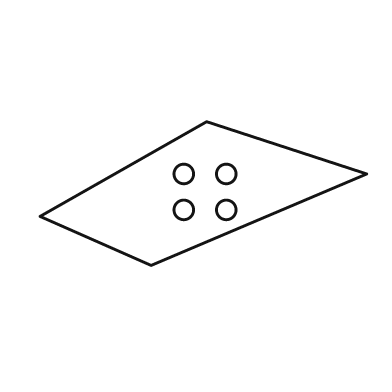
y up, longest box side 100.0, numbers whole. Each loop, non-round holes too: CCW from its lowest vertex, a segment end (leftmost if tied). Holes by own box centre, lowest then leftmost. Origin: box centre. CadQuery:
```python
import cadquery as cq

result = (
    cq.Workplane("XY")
    .moveTo(-16.0, -22.0)
    .lineTo(50.0, 6.0)
    .lineTo(1.0, 22.0)
    .lineTo(-50.0, -7.0)
    .close()
    .moveTo(-6.0, -5.0)
    .circle(3.0)
    .moveTo(7.0, -5.0)
    .circle(3.0)
    .moveTo(-6.0, 6.0)
    .circle(3.0)
    .moveTo(7.0, 6.0)
    .circle(3.0)
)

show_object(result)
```